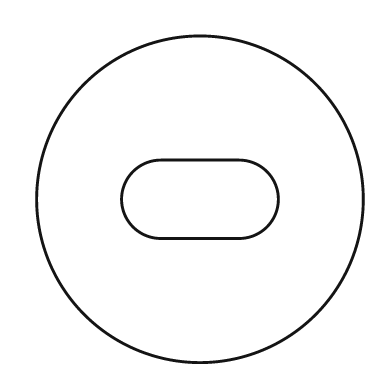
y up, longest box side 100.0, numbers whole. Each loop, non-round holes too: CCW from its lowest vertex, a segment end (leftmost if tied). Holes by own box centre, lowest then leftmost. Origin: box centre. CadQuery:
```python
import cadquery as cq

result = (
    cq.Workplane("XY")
    .moveTo(0.0, 0.0)
    .circle(50.0)
    .moveTo(-12.0, -12.0)
    .lineTo(12.0, -12.0)
    .threePointArc((24.0, 0.0), (12.0, 12.0))
    .lineTo(-12.0, 12.0)
    .threePointArc((-24.0, 0.0), (-12.0, -12.0))
    .close()
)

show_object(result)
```